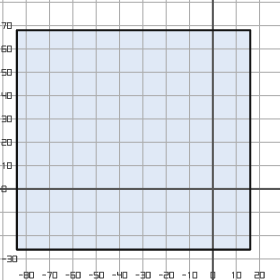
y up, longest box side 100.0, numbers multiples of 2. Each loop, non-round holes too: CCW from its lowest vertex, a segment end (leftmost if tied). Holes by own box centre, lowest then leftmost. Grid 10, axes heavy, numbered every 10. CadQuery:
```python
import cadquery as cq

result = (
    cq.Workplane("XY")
    .moveTo(-84.0, -26.0)
    .lineTo(16.0, -26.0)
    .lineTo(16.0, 68.0)
    .lineTo(-84.0, 68.0)
    .close()
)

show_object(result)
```